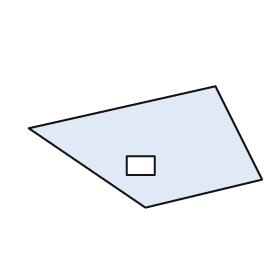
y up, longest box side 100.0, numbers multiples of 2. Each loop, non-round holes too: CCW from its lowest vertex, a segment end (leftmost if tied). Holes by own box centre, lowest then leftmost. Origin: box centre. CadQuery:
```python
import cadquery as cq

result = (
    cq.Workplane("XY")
    .moveTo(0.0, -26.0)
    .lineTo(50.0, -14.0)
    .lineTo(30.0, 26.0)
    .lineTo(-50.0, 8.0)
    .close()
    .moveTo(-8.0, -12.0)
    .lineTo(4.0, -12.0)
    .lineTo(4.0, -4.0)
    .lineTo(-8.0, -4.0)
    .close()
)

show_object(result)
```